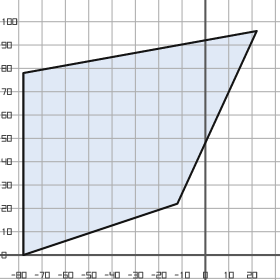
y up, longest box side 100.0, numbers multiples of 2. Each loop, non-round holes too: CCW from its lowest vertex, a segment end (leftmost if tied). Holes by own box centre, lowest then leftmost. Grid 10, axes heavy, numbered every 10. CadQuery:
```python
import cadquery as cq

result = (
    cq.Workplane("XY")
    .moveTo(-78.0, 0.0)
    .lineTo(-12.0, 22.0)
    .lineTo(22.0, 96.0)
    .lineTo(-78.0, 78.0)
    .close()
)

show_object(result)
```